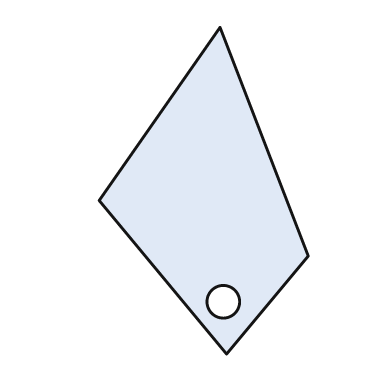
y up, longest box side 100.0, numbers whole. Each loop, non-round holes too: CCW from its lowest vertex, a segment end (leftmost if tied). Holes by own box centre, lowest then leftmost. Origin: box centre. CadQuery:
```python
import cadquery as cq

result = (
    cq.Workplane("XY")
    .moveTo(7.0, -50.0)
    .lineTo(32.0, -20.0)
    .lineTo(5.0, 50.0)
    .lineTo(-32.0, -3.0)
    .close()
    .moveTo(6.0, -34.0)
    .circle(5.0)
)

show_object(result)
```